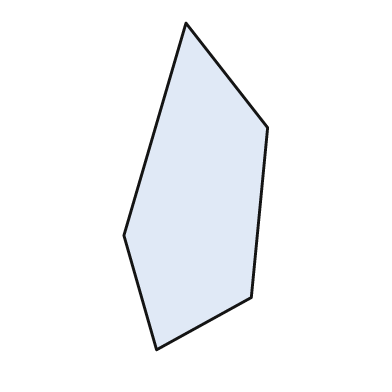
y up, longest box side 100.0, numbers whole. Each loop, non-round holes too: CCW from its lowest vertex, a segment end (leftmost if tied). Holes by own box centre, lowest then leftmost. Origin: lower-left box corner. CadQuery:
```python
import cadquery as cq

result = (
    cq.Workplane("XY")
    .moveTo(10.0, 0.0)
    .lineTo(39.0, 16.0)
    .lineTo(44.0, 68.0)
    .lineTo(19.0, 100.0)
    .lineTo(0.0, 35.0)
    .close()
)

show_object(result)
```